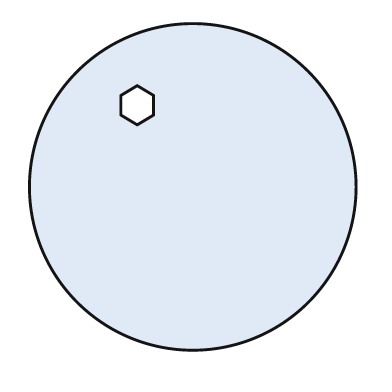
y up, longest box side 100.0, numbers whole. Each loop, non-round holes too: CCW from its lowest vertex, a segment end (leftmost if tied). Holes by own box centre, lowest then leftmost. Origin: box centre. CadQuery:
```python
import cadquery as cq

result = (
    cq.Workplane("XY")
    .moveTo(0.0, 0.0)
    .circle(50.0)
    .moveTo(-17.0, 19.0)
    .lineTo(-12.0, 22.0)
    .lineTo(-12.0, 28.0)
    .lineTo(-17.0, 31.0)
    .lineTo(-22.0, 28.0)
    .lineTo(-22.0, 22.0)
    .close()
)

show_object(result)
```